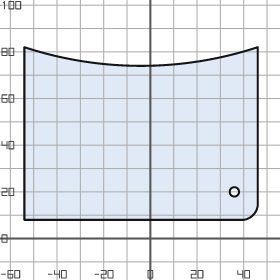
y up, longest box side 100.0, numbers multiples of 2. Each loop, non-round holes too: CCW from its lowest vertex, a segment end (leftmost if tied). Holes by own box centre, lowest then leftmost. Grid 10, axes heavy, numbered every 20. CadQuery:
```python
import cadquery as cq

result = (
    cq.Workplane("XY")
    .moveTo(-54.0, 8.0)
    .lineTo(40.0, 8.0)
    .threePointArc((44.0, 10.0), (46.0, 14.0))
    .lineTo(46.0, 82.0)
    .threePointArc((-4.0, 74.0), (-54.0, 82.0))
    .close()
    .moveTo(36.0, 20.0)
    .circle(2.0)
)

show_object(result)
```